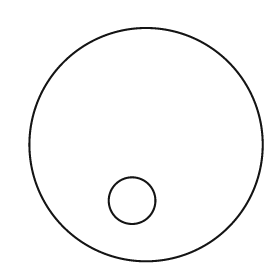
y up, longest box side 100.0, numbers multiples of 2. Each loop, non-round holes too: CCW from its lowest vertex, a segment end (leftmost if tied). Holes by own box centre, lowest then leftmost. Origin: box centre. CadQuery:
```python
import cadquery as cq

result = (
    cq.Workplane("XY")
    .moveTo(0.0, 0.0)
    .circle(50.0)
    .moveTo(-6.0, -24.0)
    .circle(10.0)
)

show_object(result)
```